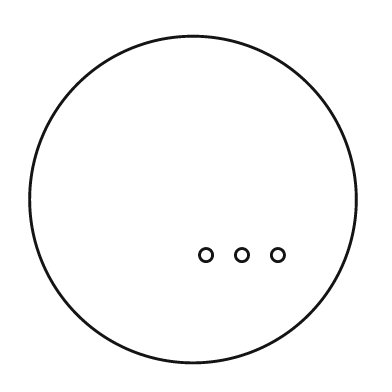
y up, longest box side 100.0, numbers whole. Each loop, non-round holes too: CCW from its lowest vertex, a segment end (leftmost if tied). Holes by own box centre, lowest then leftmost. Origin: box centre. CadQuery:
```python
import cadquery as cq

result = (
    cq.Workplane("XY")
    .moveTo(0.0, 0.0)
    .circle(50.0)
    .moveTo(4.0, -17.0)
    .circle(2.0)
    .moveTo(15.0, -17.0)
    .circle(2.0)
    .moveTo(26.0, -17.0)
    .circle(2.0)
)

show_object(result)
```